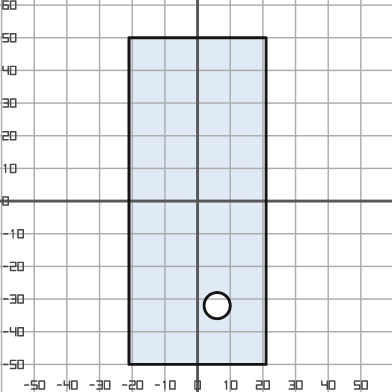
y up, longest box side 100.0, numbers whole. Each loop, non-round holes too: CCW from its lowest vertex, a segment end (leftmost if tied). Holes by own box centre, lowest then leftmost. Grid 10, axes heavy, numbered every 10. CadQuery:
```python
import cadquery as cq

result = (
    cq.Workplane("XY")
    .moveTo(-21.0, -50.0)
    .lineTo(21.0, -50.0)
    .lineTo(21.0, 50.0)
    .lineTo(-21.0, 50.0)
    .close()
    .moveTo(6.0, -32.0)
    .circle(4.0)
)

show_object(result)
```